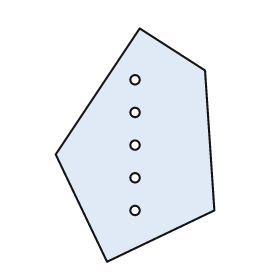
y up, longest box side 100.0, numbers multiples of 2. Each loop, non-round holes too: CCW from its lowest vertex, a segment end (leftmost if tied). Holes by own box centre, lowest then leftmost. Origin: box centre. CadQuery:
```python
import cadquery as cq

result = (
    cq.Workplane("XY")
    .moveTo(-12.0, -50.0)
    .lineTo(34.0, -28.0)
    .lineTo(30.0, 32.0)
    .lineTo(2.0, 50.0)
    .lineTo(-34.0, -4.0)
    .close()
    .moveTo(0.0, -28.0)
    .circle(2.0)
    .moveTo(0.0, -14.0)
    .circle(2.0)
    .moveTo(0.0, 0.0)
    .circle(2.0)
    .moveTo(0.0, 14.0)
    .circle(2.0)
    .moveTo(0.0, 28.0)
    .circle(2.0)
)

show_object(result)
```